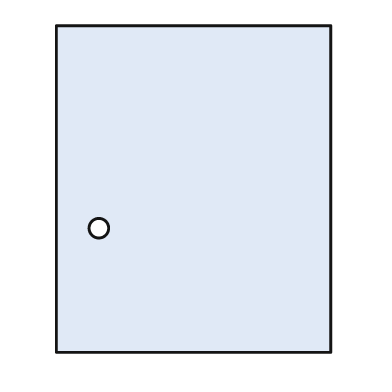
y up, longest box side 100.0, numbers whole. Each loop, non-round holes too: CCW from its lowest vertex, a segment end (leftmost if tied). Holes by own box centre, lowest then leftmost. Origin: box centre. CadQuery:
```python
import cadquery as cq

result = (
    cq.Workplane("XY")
    .moveTo(-42.0, -50.0)
    .lineTo(42.0, -50.0)
    .lineTo(42.0, 50.0)
    .lineTo(-42.0, 50.0)
    .close()
    .moveTo(-29.0, -12.0)
    .circle(3.0)
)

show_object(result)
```